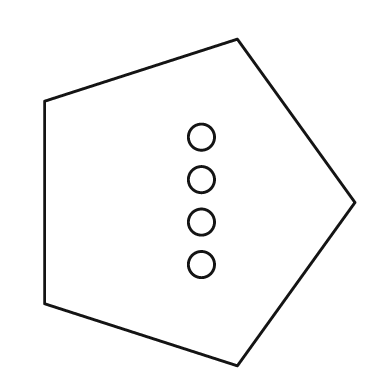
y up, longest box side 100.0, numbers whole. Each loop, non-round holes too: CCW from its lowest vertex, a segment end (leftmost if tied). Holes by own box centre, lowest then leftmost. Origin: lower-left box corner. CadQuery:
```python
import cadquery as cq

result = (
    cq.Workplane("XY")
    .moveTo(59.0, 0.0)
    .lineTo(95.0, 50.0)
    .lineTo(59.0, 100.0)
    .lineTo(0.0, 81.0)
    .lineTo(0.0, 19.0)
    .close()
    .moveTo(48.0, 31.0)
    .circle(4.0)
    .moveTo(48.0, 44.0)
    .circle(4.0)
    .moveTo(48.0, 57.0)
    .circle(4.0)
    .moveTo(48.0, 70.0)
    .circle(4.0)
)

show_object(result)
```